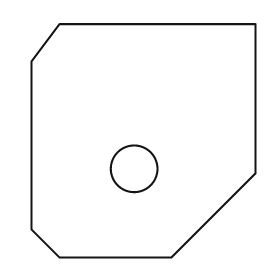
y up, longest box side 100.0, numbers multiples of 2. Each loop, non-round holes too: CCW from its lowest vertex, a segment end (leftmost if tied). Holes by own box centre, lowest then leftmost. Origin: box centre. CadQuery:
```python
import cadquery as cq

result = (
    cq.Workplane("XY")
    .moveTo(-36.0, -50.0)
    .lineTo(12.0, -50.0)
    .lineTo(48.0, -14.0)
    .lineTo(48.0, 50.0)
    .lineTo(-36.0, 50.0)
    .lineTo(-48.0, 34.0)
    .lineTo(-48.0, -38.0)
    .close()
    .moveTo(-4.0, -12.0)
    .circle(10.0)
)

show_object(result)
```